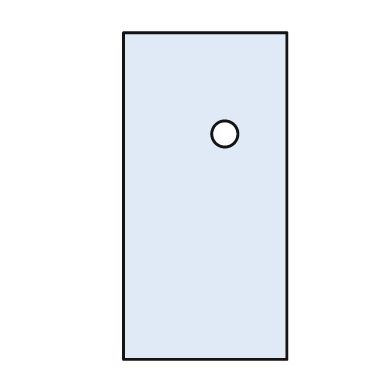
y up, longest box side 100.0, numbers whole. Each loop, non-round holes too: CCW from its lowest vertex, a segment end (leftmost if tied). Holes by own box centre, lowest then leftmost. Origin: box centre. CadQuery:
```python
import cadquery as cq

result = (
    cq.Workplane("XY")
    .moveTo(-25.0, -50.0)
    .lineTo(25.0, -50.0)
    .lineTo(25.0, 50.0)
    .lineTo(-25.0, 50.0)
    .close()
    .moveTo(6.0, 19.0)
    .circle(4.0)
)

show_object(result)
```